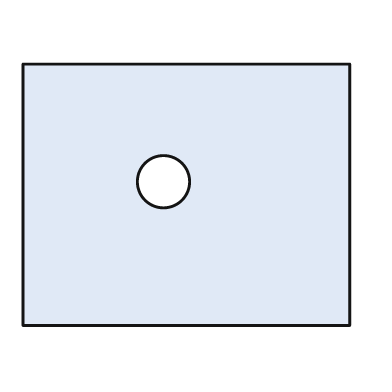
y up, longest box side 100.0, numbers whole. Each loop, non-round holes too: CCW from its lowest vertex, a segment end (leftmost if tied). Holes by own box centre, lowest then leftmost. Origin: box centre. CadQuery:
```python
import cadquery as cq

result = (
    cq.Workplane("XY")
    .moveTo(-50.0, -40.0)
    .lineTo(50.0, -40.0)
    .lineTo(50.0, 40.0)
    .lineTo(-50.0, 40.0)
    .close()
    .moveTo(-7.0, 4.0)
    .circle(8.0)
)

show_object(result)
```